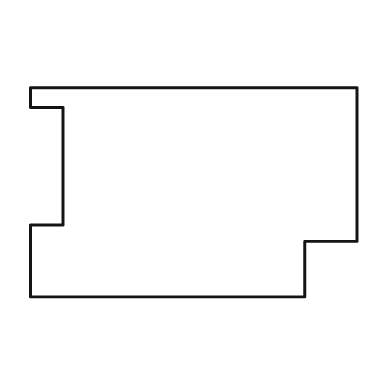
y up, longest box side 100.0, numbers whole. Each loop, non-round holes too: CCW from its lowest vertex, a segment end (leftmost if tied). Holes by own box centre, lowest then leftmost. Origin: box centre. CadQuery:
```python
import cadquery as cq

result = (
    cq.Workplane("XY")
    .moveTo(-50.0, -32.0)
    .lineTo(34.0, -32.0)
    .lineTo(34.0, -15.0)
    .lineTo(50.0, -15.0)
    .lineTo(50.0, 32.0)
    .lineTo(-50.0, 32.0)
    .lineTo(-50.0, 26.0)
    .lineTo(-40.0, 26.0)
    .lineTo(-40.0, -10.0)
    .lineTo(-50.0, -10.0)
    .close()
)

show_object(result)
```